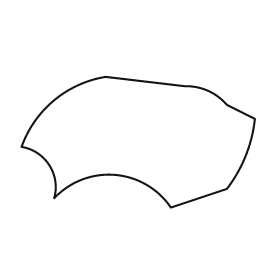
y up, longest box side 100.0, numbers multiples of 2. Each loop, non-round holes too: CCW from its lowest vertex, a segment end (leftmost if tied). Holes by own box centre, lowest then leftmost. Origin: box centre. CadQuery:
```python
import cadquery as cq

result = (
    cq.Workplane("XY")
    .moveTo(14.0, -28.0)
    .lineTo(38.0, -20.0)
    .threePointArc((46.0, -6.0), (50.0, 10.0))
    .lineTo(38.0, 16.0)
    .threePointArc((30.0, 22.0), (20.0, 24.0))
    .lineTo(-14.0, 28.0)
    .threePointArc((-36.0, 18.0), (-50.0, -2.0))
    .threePointArc((-38.0, -10.0), (-36.0, -24.0))
    .threePointArc((-10.0, -14.0), (14.0, -28.0))
    .close()
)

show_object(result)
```